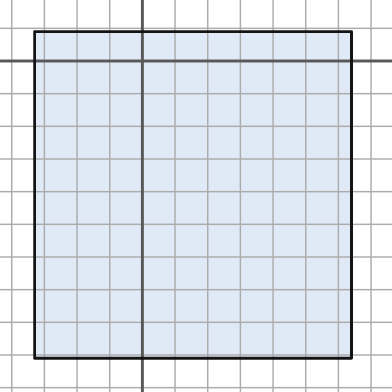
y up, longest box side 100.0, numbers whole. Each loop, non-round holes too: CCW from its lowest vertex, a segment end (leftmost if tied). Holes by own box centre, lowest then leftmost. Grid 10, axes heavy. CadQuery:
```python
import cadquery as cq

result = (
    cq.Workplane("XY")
    .moveTo(-33.0, -91.0)
    .lineTo(64.0, -91.0)
    .lineTo(64.0, 9.0)
    .lineTo(-33.0, 9.0)
    .close()
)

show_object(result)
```